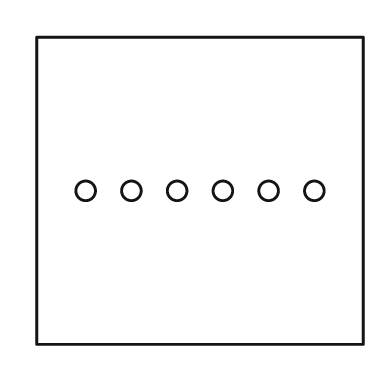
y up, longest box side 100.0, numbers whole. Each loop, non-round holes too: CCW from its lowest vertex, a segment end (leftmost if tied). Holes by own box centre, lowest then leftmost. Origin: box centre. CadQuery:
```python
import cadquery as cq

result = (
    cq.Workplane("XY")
    .moveTo(-50.0, -47.0)
    .lineTo(50.0, -47.0)
    .lineTo(50.0, 47.0)
    .lineTo(-50.0, 47.0)
    .close()
    .moveTo(-35.0, 0.0)
    .circle(3.0)
    .moveTo(-21.0, 0.0)
    .circle(3.0)
    .moveTo(-7.0, 0.0)
    .circle(3.0)
    .moveTo(7.0, 0.0)
    .circle(3.0)
    .moveTo(21.0, 0.0)
    .circle(3.0)
    .moveTo(35.0, 0.0)
    .circle(3.0)
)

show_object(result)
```